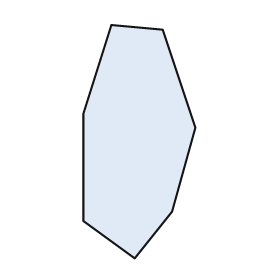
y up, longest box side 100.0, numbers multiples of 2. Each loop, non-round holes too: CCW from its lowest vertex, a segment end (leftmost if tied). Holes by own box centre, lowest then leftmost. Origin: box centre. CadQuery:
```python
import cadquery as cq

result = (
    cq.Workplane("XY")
    .moveTo(-2.0, -50.0)
    .lineTo(14.0, -30.0)
    .lineTo(24.0, 6.0)
    .lineTo(10.0, 48.0)
    .lineTo(-12.0, 50.0)
    .lineTo(-24.0, 12.0)
    .lineTo(-24.0, -34.0)
    .close()
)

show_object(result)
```